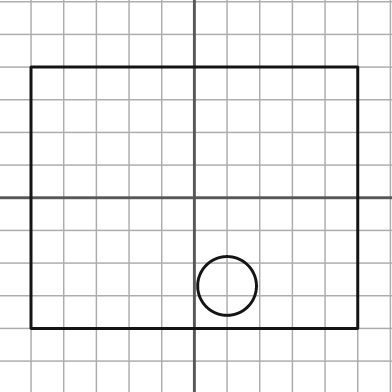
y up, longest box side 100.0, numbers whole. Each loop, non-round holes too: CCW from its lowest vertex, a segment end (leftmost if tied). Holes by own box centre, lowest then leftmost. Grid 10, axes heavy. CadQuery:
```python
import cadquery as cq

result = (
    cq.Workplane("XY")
    .moveTo(-50.0, -40.0)
    .lineTo(50.0, -40.0)
    .lineTo(50.0, 40.0)
    .lineTo(-50.0, 40.0)
    .close()
    .moveTo(10.0, -27.0)
    .circle(9.0)
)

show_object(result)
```